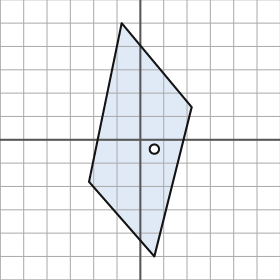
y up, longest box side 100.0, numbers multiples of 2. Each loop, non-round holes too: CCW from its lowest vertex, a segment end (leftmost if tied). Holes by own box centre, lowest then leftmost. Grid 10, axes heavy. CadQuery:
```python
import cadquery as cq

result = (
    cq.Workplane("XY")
    .moveTo(6.0, -50.0)
    .lineTo(22.0, 14.0)
    .lineTo(-8.0, 50.0)
    .lineTo(-22.0, -18.0)
    .close()
    .moveTo(6.0, -4.0)
    .circle(2.0)
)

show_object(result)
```